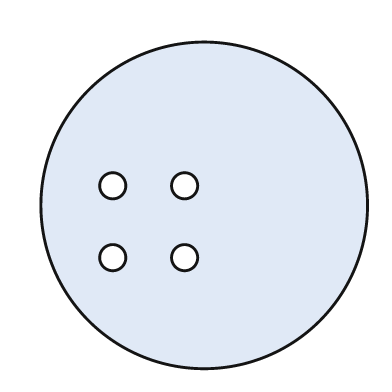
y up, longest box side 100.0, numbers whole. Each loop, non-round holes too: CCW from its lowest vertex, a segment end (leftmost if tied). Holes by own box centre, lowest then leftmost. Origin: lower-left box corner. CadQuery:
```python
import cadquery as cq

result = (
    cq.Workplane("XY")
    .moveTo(50.0, 50.0)
    .circle(50.0)
    .moveTo(22.0, 34.0)
    .circle(4.0)
    .moveTo(44.0, 34.0)
    .circle(4.0)
    .moveTo(22.0, 56.0)
    .circle(4.0)
    .moveTo(44.0, 56.0)
    .circle(4.0)
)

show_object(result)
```